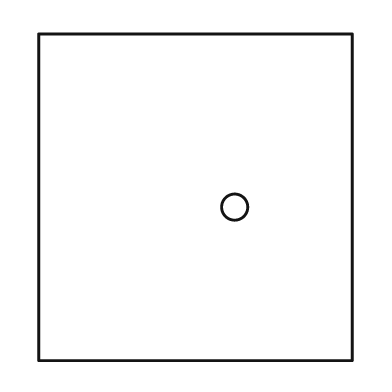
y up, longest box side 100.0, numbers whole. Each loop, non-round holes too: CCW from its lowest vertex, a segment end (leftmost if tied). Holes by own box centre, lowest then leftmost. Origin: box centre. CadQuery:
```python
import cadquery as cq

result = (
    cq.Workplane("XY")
    .moveTo(-48.0, -50.0)
    .lineTo(48.0, -50.0)
    .lineTo(48.0, 50.0)
    .lineTo(-48.0, 50.0)
    .close()
    .moveTo(12.0, -3.0)
    .circle(4.0)
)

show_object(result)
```